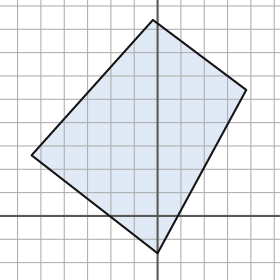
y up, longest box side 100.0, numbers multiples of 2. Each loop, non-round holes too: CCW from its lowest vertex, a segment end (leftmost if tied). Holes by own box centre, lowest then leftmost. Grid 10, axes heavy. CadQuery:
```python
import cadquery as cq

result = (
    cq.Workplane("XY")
    .moveTo(0.0, -16.0)
    .lineTo(38.0, 54.0)
    .lineTo(-2.0, 84.0)
    .lineTo(-54.0, 26.0)
    .close()
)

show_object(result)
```